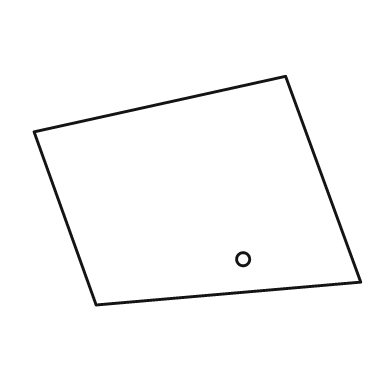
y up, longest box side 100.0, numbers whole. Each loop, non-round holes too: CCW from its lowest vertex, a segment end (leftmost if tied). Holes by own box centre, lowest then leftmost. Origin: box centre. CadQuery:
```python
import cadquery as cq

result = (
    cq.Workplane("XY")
    .moveTo(-31.0, -35.0)
    .lineTo(50.0, -28.0)
    .lineTo(27.0, 35.0)
    .lineTo(-50.0, 18.0)
    .close()
    .moveTo(14.0, -21.0)
    .circle(2.0)
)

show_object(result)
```